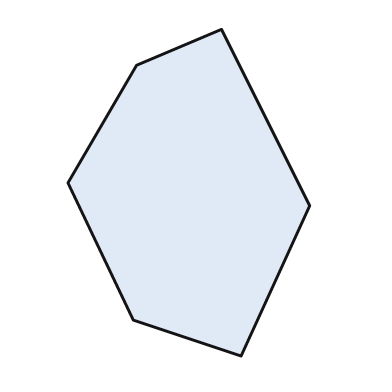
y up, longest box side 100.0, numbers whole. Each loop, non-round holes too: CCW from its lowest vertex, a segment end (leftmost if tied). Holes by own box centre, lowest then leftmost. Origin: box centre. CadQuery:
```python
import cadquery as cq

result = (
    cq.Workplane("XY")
    .moveTo(16.0, -50.0)
    .lineTo(37.0, -4.0)
    .lineTo(10.0, 50.0)
    .lineTo(-16.0, 39.0)
    .lineTo(-37.0, 3.0)
    .lineTo(-17.0, -39.0)
    .close()
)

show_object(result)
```